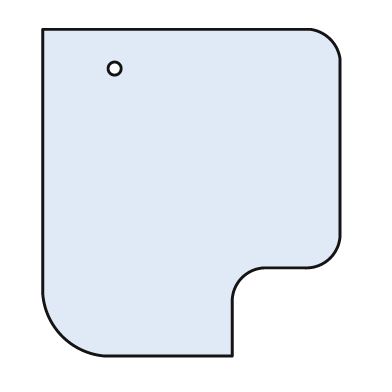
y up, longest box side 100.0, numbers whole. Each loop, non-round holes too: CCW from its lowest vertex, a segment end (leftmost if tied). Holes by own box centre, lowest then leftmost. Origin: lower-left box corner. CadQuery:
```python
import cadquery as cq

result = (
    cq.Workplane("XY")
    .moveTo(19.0, 0.0)
    .lineTo(58.0, 0.0)
    .lineTo(58.0, 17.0)
    .threePointArc((61.0, 24.0), (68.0, 27.0))
    .lineTo(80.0, 27.0)
    .threePointArc((88.0, 30.0), (91.0, 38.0))
    .lineTo(91.0, 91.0)
    .threePointArc((88.0, 97.0), (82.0, 100.0))
    .lineTo(0.0, 100.0)
    .lineTo(0.0, 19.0)
    .threePointArc((6.0, 6.0), (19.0, 0.0))
    .close()
    .moveTo(22.0, 88.0)
    .circle(2.0)
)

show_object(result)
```